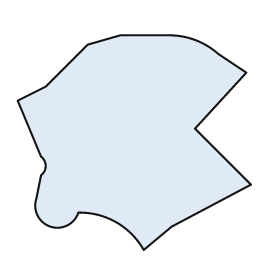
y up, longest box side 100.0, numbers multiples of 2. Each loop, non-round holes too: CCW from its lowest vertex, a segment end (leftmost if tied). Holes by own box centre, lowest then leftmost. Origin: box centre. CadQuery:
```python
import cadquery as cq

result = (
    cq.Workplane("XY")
    .moveTo(4.0, -46.0)
    .lineTo(16.0, -36.0)
    .lineTo(50.0, -18.0)
    .lineTo(26.0, 6.0)
    .lineTo(48.0, 30.0)
    .lineTo(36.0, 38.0)
    .threePointArc((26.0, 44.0), (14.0, 46.0))
    .lineTo(-6.0, 46.0)
    .lineTo(-20.0, 42.0)
    .lineTo(-38.0, 24.0)
    .lineTo(-50.0, 18.0)
    .lineTo(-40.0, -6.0)
    .threePointArc((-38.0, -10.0), (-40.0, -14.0))
    .lineTo(-42.0, -24.0)
    .threePointArc((-36.0, -36.0), (-24.0, -30.0))
    .threePointArc((-8.0, -34.0), (4.0, -46.0))
    .close()
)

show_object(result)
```